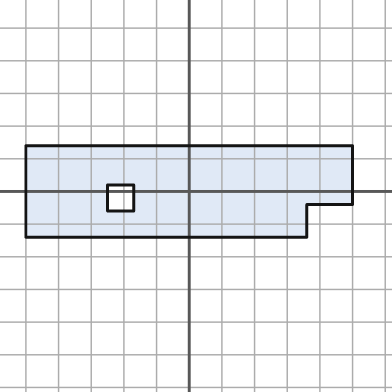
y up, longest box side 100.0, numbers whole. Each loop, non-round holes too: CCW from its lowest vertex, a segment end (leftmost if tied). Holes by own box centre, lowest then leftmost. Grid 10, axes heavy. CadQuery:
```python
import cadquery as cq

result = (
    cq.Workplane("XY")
    .moveTo(-50.0, -14.0)
    .lineTo(36.0, -14.0)
    .lineTo(36.0, -4.0)
    .lineTo(50.0, -4.0)
    .lineTo(50.0, 14.0)
    .lineTo(-50.0, 14.0)
    .close()
    .moveTo(-25.0, -6.0)
    .lineTo(-17.0, -6.0)
    .lineTo(-17.0, 2.0)
    .lineTo(-25.0, 2.0)
    .close()
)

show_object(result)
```